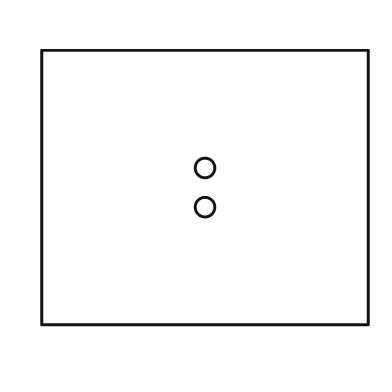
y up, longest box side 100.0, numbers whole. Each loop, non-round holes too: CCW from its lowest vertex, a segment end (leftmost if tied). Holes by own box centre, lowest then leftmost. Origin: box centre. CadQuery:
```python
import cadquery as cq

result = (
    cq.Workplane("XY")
    .moveTo(-50.0, -42.0)
    .lineTo(50.0, -42.0)
    .lineTo(50.0, 42.0)
    .lineTo(-50.0, 42.0)
    .close()
    .moveTo(0.0, -6.0)
    .circle(3.0)
    .moveTo(0.0, 6.0)
    .circle(3.0)
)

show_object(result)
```